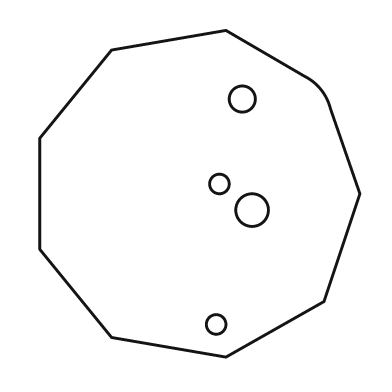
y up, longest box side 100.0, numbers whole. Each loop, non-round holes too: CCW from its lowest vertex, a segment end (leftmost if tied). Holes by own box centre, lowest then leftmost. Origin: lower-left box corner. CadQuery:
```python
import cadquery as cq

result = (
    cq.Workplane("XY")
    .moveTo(57.0, 0.0)
    .lineTo(87.0, 17.0)
    .lineTo(98.0, 50.0)
    .lineTo(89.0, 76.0)
    .threePointArc((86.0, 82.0), (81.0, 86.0))
    .lineTo(57.0, 100.0)
    .lineTo(22.0, 94.0)
    .lineTo(0.0, 67.0)
    .lineTo(0.0, 33.0)
    .lineTo(22.0, 6.0)
    .close()
    .moveTo(54.0, 10.0)
    .circle(3.0)
    .moveTo(65.0, 45.0)
    .circle(5.0)
    .moveTo(55.0, 53.0)
    .circle(3.0)
    .moveTo(62.0, 79.0)
    .circle(4.0)
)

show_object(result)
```